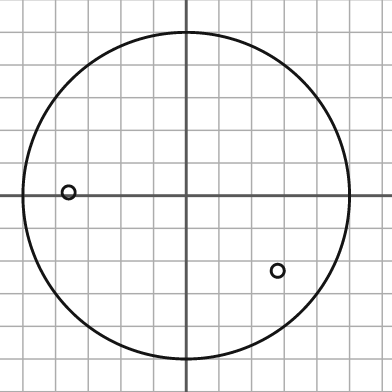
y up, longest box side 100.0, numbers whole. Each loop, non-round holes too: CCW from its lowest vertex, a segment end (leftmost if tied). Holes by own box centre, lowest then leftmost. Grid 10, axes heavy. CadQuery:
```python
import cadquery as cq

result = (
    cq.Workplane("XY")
    .moveTo(0.0, 0.0)
    .circle(50.0)
    .moveTo(28.0, -23.0)
    .circle(2.0)
    .moveTo(-36.0, 1.0)
    .circle(2.0)
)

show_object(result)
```